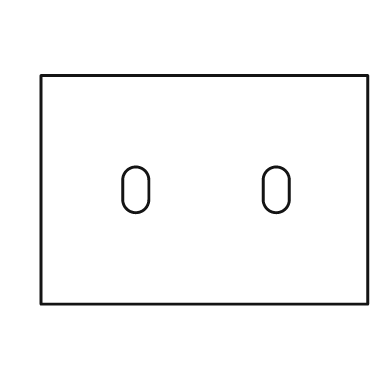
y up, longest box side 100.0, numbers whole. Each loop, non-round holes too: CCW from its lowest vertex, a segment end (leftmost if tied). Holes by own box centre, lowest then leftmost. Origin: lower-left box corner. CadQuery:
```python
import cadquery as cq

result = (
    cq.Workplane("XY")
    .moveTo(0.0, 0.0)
    .lineTo(100.0, 0.0)
    .lineTo(100.0, 70.0)
    .lineTo(0.0, 70.0)
    .close()
    .moveTo(25.0, 32.0)
    .threePointArc((29.0, 28.0), (33.0, 32.0))
    .lineTo(33.0, 38.0)
    .threePointArc((29.0, 42.0), (25.0, 38.0))
    .close()
    .moveTo(68.0, 32.0)
    .threePointArc((72.0, 28.0), (76.0, 32.0))
    .lineTo(76.0, 38.0)
    .threePointArc((72.0, 42.0), (68.0, 38.0))
    .close()
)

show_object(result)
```